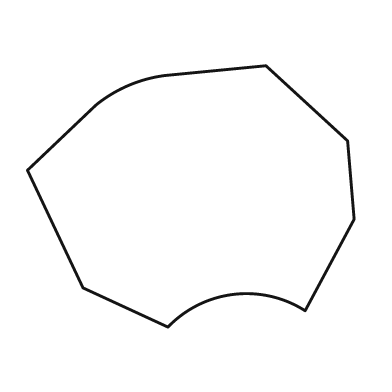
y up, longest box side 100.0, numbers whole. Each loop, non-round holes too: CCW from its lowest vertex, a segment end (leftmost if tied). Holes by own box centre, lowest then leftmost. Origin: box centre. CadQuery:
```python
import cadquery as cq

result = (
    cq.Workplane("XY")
    .moveTo(-7.0, -40.0)
    .threePointArc((13.0, -30.0), (35.0, -35.0))
    .lineTo(50.0, -7.0)
    .lineTo(48.0, 17.0)
    .lineTo(23.0, 40.0)
    .lineTo(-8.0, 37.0)
    .threePointArc((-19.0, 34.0), (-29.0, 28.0))
    .lineTo(-50.0, 8.0)
    .lineTo(-33.0, -28.0)
    .close()
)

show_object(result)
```